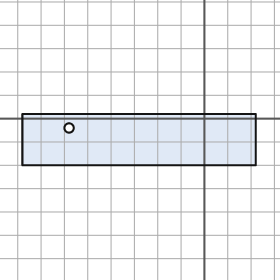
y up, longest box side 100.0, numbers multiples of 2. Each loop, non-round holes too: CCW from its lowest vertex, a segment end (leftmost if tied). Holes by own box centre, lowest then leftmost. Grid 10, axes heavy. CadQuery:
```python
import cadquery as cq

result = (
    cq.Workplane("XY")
    .moveTo(-78.0, -20.0)
    .lineTo(22.0, -20.0)
    .lineTo(22.0, 2.0)
    .lineTo(-78.0, 2.0)
    .close()
    .moveTo(-58.0, -4.0)
    .circle(2.0)
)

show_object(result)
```